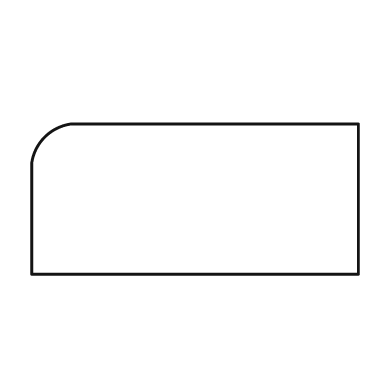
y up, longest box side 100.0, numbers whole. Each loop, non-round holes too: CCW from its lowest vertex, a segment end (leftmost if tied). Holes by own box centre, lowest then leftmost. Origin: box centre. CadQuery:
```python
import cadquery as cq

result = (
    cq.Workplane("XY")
    .moveTo(-50.0, -23.0)
    .lineTo(50.0, -23.0)
    .lineTo(50.0, 23.0)
    .lineTo(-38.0, 23.0)
    .threePointArc((-46.0, 19.0), (-50.0, 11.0))
    .close()
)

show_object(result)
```